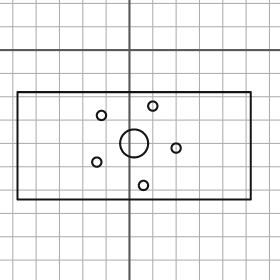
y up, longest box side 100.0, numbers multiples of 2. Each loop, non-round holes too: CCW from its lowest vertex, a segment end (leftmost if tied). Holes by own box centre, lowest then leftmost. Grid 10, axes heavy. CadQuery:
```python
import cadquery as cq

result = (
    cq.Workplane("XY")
    .moveTo(-48.0, -64.0)
    .lineTo(52.0, -64.0)
    .lineTo(52.0, -18.0)
    .lineTo(-48.0, -18.0)
    .close()
    .moveTo(6.0, -58.0)
    .circle(2.0)
    .moveTo(-14.0, -48.0)
    .circle(2.0)
    .moveTo(20.0, -42.0)
    .circle(2.0)
    .moveTo(2.0, -40.0)
    .circle(6.0)
    .moveTo(-12.0, -28.0)
    .circle(2.0)
    .moveTo(10.0, -24.0)
    .circle(2.0)
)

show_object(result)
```